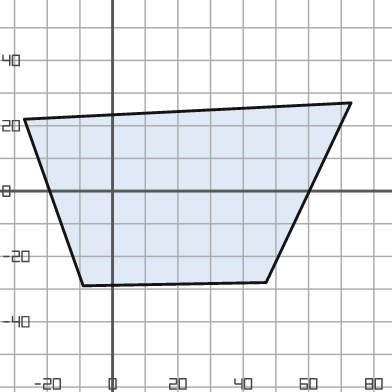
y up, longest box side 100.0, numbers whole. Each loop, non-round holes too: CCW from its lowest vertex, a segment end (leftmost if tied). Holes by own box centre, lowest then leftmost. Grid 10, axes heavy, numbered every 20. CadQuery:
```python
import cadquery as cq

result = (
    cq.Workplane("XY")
    .moveTo(-9.0, -29.0)
    .lineTo(47.0, -28.0)
    .lineTo(73.0, 27.0)
    .lineTo(-27.0, 22.0)
    .close()
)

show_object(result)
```